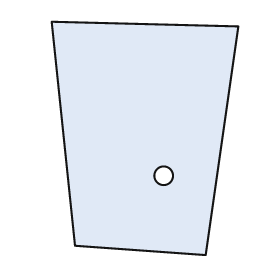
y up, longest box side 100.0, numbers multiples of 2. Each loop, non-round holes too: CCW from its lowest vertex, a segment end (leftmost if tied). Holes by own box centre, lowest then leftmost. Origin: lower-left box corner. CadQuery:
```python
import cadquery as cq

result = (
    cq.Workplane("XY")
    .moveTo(66.0, 0.0)
    .lineTo(80.0, 98.0)
    .lineTo(0.0, 100.0)
    .lineTo(10.0, 4.0)
    .close()
    .moveTo(48.0, 34.0)
    .circle(4.0)
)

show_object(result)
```